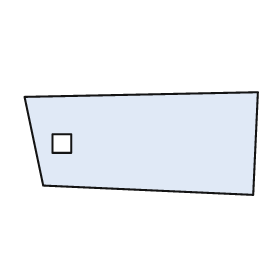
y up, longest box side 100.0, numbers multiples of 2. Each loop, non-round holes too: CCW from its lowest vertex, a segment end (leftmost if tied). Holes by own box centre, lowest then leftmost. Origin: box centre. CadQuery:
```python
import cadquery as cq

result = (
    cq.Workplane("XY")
    .moveTo(48.0, -22.0)
    .lineTo(50.0, 22.0)
    .lineTo(-50.0, 20.0)
    .lineTo(-42.0, -18.0)
    .close()
    .moveTo(-38.0, -4.0)
    .lineTo(-30.0, -4.0)
    .lineTo(-30.0, 4.0)
    .lineTo(-38.0, 4.0)
    .close()
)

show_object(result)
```